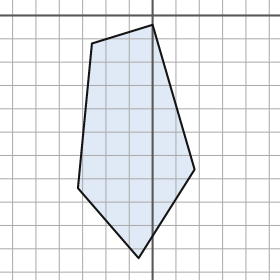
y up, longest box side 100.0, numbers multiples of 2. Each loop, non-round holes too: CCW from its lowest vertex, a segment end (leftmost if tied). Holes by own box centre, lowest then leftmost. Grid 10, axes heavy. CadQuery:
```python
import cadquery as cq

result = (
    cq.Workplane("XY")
    .moveTo(-6.0, -104.0)
    .lineTo(18.0, -66.0)
    .lineTo(0.0, -4.0)
    .lineTo(-26.0, -12.0)
    .lineTo(-32.0, -74.0)
    .close()
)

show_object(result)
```